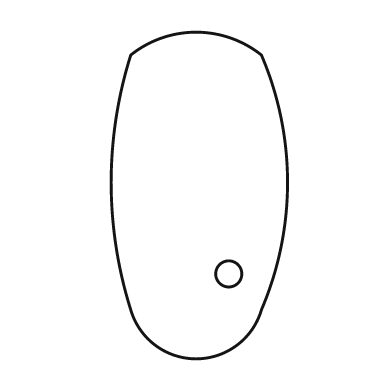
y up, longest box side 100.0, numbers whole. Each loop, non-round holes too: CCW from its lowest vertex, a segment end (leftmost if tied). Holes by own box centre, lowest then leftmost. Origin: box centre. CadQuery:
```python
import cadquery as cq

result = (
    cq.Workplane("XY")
    .moveTo(-21.0, -35.0)
    .threePointArc((-1.0, -50.0), (19.0, -35.0))
    .threePointArc((27.0, 4.0), (19.0, 43.0))
    .threePointArc((-1.0, 50.0), (-21.0, 43.0))
    .threePointArc((-27.0, 4.0), (-21.0, -35.0))
    .close()
    .moveTo(9.0, -24.0)
    .circle(4.0)
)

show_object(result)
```